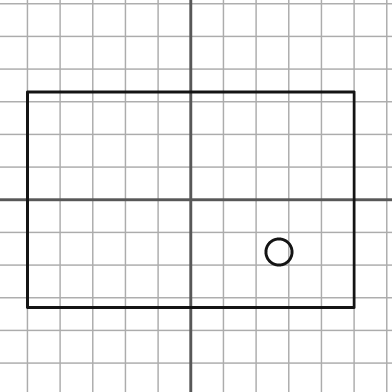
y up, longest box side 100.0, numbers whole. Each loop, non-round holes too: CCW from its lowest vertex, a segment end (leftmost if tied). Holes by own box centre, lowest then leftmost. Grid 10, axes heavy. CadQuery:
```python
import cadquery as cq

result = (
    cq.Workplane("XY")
    .moveTo(-50.0, -33.0)
    .lineTo(50.0, -33.0)
    .lineTo(50.0, 33.0)
    .lineTo(-50.0, 33.0)
    .close()
    .moveTo(27.0, -16.0)
    .circle(4.0)
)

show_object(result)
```